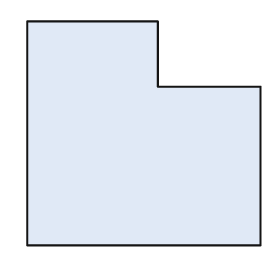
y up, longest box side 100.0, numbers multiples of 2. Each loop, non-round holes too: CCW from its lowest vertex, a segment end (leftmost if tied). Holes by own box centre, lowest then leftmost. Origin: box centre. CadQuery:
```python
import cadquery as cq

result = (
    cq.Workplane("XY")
    .moveTo(-50.0, -48.0)
    .lineTo(50.0, -48.0)
    .lineTo(50.0, 20.0)
    .lineTo(6.0, 20.0)
    .lineTo(6.0, 48.0)
    .lineTo(-50.0, 48.0)
    .close()
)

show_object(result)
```